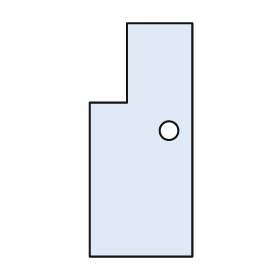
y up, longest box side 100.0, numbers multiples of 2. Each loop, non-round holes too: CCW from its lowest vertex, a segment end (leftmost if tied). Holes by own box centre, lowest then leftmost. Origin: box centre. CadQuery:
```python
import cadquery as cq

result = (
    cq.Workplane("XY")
    .moveTo(-22.0, -50.0)
    .lineTo(22.0, -50.0)
    .lineTo(22.0, 50.0)
    .lineTo(-6.0, 50.0)
    .lineTo(-6.0, 16.0)
    .lineTo(-22.0, 16.0)
    .close()
    .moveTo(12.0, 4.0)
    .circle(4.0)
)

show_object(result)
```